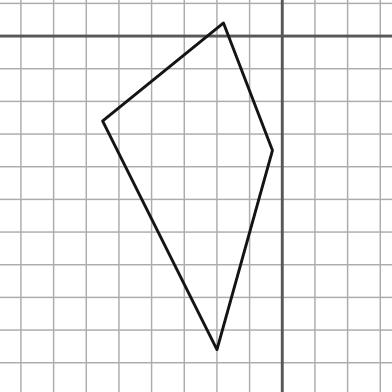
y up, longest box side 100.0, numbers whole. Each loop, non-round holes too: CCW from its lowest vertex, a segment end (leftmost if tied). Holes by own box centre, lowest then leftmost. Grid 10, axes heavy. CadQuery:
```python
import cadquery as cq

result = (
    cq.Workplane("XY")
    .moveTo(-20.0, -96.0)
    .lineTo(-3.0, -35.0)
    .lineTo(-18.0, 4.0)
    .lineTo(-55.0, -26.0)
    .close()
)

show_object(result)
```